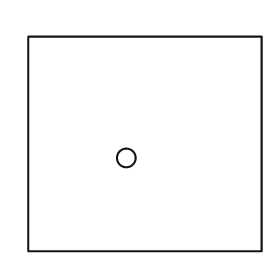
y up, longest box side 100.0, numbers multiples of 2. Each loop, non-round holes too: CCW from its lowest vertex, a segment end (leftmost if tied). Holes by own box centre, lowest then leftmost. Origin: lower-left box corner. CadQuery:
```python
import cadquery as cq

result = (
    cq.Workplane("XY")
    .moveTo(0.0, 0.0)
    .lineTo(100.0, 0.0)
    .lineTo(100.0, 92.0)
    .lineTo(0.0, 92.0)
    .close()
    .moveTo(42.0, 40.0)
    .circle(4.0)
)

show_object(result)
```